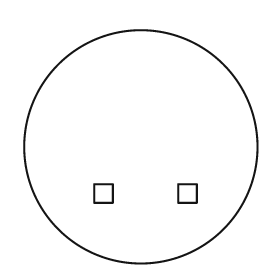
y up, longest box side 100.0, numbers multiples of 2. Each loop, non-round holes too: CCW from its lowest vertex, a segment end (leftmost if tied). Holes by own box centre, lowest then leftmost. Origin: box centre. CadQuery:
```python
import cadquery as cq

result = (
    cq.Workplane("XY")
    .moveTo(0.0, 0.0)
    .circle(50.0)
    .moveTo(-20.0, -24.0)
    .lineTo(-12.0, -24.0)
    .lineTo(-12.0, -16.0)
    .lineTo(-20.0, -16.0)
    .close()
    .moveTo(16.0, -24.0)
    .lineTo(24.0, -24.0)
    .lineTo(24.0, -16.0)
    .lineTo(16.0, -16.0)
    .close()
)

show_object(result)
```